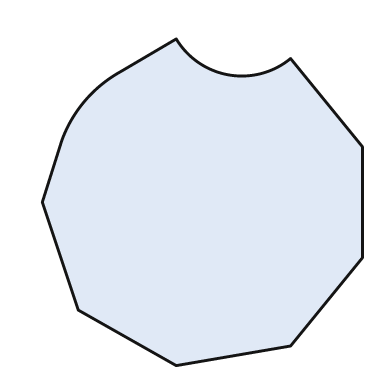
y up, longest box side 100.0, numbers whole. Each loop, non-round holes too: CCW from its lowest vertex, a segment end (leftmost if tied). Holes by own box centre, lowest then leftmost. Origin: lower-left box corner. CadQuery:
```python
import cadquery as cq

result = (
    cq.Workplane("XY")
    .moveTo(41.0, 0.0)
    .lineTo(76.0, 6.0)
    .lineTo(98.0, 33.0)
    .lineTo(98.0, 67.0)
    .lineTo(76.0, 94.0)
    .threePointArc((57.0, 89.0), (41.0, 100.0))
    .lineTo(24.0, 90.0)
    .threePointArc((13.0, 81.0), (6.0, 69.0))
    .lineTo(0.0, 50.0)
    .lineTo(11.0, 17.0)
    .close()
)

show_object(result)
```